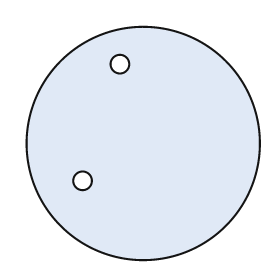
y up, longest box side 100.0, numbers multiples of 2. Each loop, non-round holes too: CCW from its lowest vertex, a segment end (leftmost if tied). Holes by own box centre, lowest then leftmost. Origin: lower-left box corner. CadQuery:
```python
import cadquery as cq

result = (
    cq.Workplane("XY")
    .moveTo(50.0, 50.0)
    .circle(50.0)
    .moveTo(24.0, 34.0)
    .circle(4.0)
    .moveTo(40.0, 84.0)
    .circle(4.0)
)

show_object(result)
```